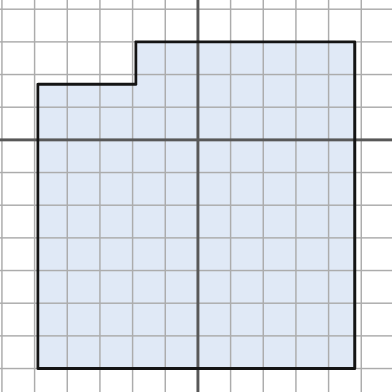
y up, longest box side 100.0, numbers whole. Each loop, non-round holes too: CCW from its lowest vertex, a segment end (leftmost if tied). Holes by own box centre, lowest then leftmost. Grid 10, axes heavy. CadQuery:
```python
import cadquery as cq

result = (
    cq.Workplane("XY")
    .moveTo(-49.0, -70.0)
    .lineTo(48.0, -70.0)
    .lineTo(48.0, 30.0)
    .lineTo(-19.0, 30.0)
    .lineTo(-19.0, 17.0)
    .lineTo(-49.0, 17.0)
    .close()
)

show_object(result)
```